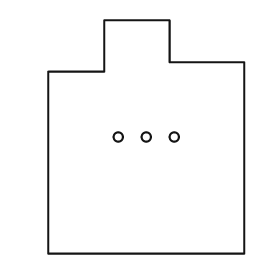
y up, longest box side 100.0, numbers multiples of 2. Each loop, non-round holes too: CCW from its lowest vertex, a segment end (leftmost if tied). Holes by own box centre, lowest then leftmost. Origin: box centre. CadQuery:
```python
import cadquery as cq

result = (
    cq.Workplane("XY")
    .moveTo(-42.0, -50.0)
    .lineTo(42.0, -50.0)
    .lineTo(42.0, 32.0)
    .lineTo(10.0, 32.0)
    .lineTo(10.0, 50.0)
    .lineTo(-18.0, 50.0)
    .lineTo(-18.0, 28.0)
    .lineTo(-42.0, 28.0)
    .close()
    .moveTo(-12.0, 0.0)
    .circle(2.0)
    .moveTo(0.0, 0.0)
    .circle(2.0)
    .moveTo(12.0, 0.0)
    .circle(2.0)
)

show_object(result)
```